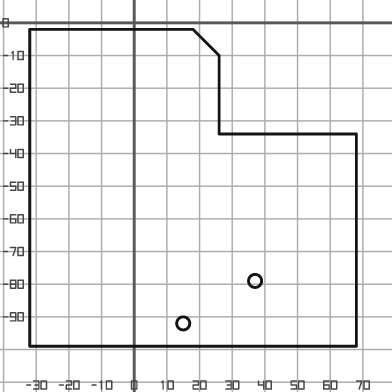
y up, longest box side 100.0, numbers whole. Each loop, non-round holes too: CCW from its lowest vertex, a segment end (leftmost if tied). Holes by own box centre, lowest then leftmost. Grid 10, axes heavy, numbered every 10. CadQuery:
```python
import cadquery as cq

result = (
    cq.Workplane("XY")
    .moveTo(-32.0, -99.0)
    .lineTo(68.0, -99.0)
    .lineTo(68.0, -34.0)
    .lineTo(26.0, -34.0)
    .lineTo(26.0, -10.0)
    .lineTo(18.0, -2.0)
    .lineTo(-32.0, -2.0)
    .close()
    .moveTo(15.0, -92.0)
    .circle(2.0)
    .moveTo(37.0, -79.0)
    .circle(2.0)
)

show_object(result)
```